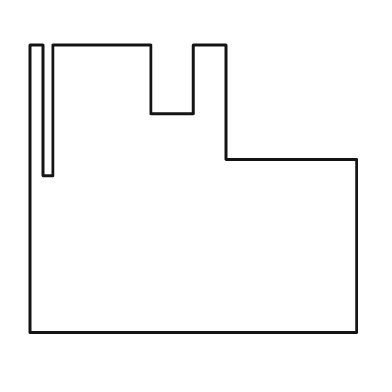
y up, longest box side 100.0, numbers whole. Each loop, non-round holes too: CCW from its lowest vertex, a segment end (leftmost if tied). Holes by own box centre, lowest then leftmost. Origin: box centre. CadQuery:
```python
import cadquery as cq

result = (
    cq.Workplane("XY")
    .moveTo(-50.0, -44.0)
    .lineTo(50.0, -44.0)
    .lineTo(50.0, 9.0)
    .lineTo(10.0, 9.0)
    .lineTo(10.0, 44.0)
    .lineTo(0.0, 44.0)
    .lineTo(0.0, 23.0)
    .lineTo(-13.0, 23.0)
    .lineTo(-13.0, 44.0)
    .lineTo(-43.0, 44.0)
    .lineTo(-43.0, 4.0)
    .lineTo(-46.0, 4.0)
    .lineTo(-46.0, 44.0)
    .lineTo(-50.0, 44.0)
    .close()
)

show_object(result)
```